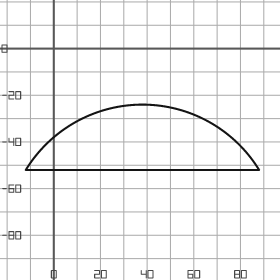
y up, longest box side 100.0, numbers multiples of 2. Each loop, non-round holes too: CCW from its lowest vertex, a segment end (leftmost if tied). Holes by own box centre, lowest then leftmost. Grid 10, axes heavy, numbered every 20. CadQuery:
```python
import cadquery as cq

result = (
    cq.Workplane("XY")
    .moveTo(-12.0, -52.0)
    .lineTo(88.0, -52.0)
    .threePointArc((38.0, -24.0), (-12.0, -52.0))
    .close()
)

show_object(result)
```